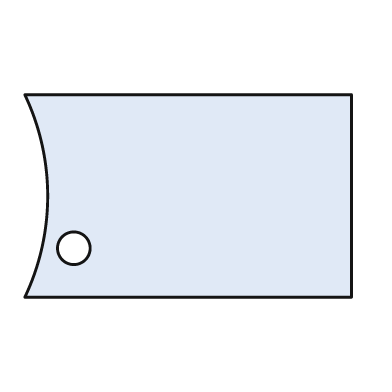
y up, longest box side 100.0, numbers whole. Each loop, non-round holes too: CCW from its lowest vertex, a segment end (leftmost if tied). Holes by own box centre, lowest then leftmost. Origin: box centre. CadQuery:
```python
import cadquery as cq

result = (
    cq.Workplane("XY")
    .moveTo(-50.0, -31.0)
    .lineTo(50.0, -31.0)
    .lineTo(50.0, 31.0)
    .lineTo(-50.0, 31.0)
    .threePointArc((-43.0, 0.0), (-50.0, -31.0))
    .close()
    .moveTo(-35.0, -16.0)
    .circle(5.0)
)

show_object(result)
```